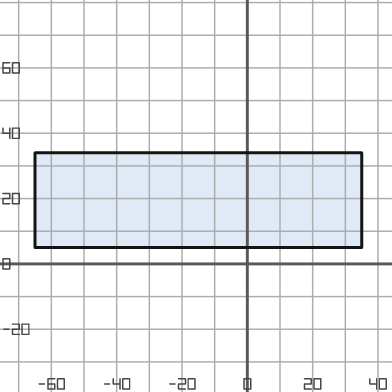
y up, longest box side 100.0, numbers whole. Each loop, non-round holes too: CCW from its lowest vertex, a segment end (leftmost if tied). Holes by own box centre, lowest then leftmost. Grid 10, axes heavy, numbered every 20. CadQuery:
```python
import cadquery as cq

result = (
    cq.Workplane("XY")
    .moveTo(-65.0, 5.0)
    .lineTo(35.0, 5.0)
    .lineTo(35.0, 34.0)
    .lineTo(-65.0, 34.0)
    .close()
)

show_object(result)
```